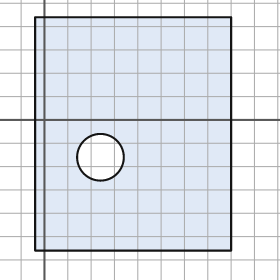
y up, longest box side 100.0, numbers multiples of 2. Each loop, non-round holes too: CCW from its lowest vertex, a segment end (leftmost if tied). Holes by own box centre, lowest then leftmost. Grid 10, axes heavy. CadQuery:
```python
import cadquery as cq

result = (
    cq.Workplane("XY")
    .moveTo(-4.0, -56.0)
    .lineTo(80.0, -56.0)
    .lineTo(80.0, 44.0)
    .lineTo(-4.0, 44.0)
    .close()
    .moveTo(24.0, -16.0)
    .circle(10.0)
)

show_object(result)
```